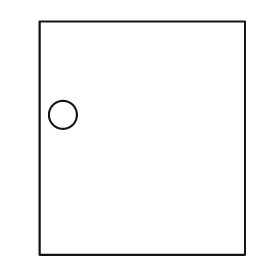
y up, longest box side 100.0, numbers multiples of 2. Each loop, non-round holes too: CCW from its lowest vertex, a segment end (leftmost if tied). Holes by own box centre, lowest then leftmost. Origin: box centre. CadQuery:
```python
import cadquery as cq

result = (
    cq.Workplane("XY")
    .moveTo(-44.0, -50.0)
    .lineTo(44.0, -50.0)
    .lineTo(44.0, 50.0)
    .lineTo(-44.0, 50.0)
    .close()
    .moveTo(-34.0, 10.0)
    .circle(6.0)
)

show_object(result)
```